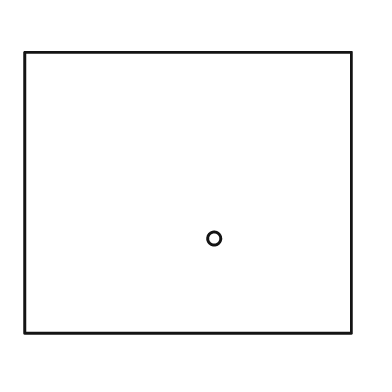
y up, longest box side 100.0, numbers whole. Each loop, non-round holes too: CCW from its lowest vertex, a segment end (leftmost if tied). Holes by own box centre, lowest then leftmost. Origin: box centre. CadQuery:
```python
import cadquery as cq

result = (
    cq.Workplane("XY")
    .moveTo(-50.0, -43.0)
    .lineTo(50.0, -43.0)
    .lineTo(50.0, 43.0)
    .lineTo(-50.0, 43.0)
    .close()
    .moveTo(8.0, -14.0)
    .circle(2.0)
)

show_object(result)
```